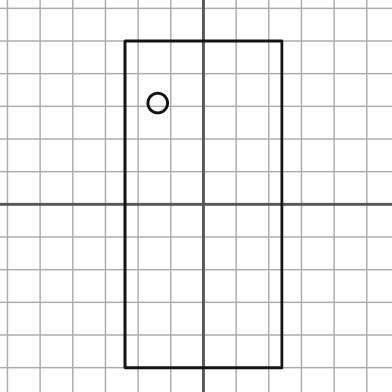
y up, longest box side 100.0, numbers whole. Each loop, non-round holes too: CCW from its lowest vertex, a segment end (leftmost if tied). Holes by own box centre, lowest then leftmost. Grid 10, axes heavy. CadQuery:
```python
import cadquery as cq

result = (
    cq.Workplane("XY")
    .moveTo(-24.0, -50.0)
    .lineTo(24.0, -50.0)
    .lineTo(24.0, 50.0)
    .lineTo(-24.0, 50.0)
    .close()
    .moveTo(-14.0, 31.0)
    .circle(3.0)
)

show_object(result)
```